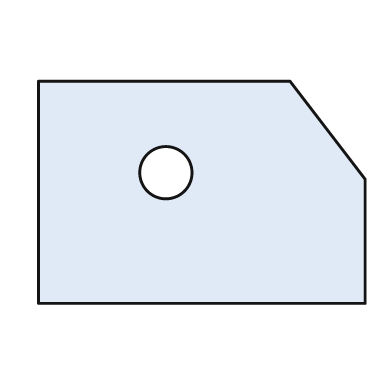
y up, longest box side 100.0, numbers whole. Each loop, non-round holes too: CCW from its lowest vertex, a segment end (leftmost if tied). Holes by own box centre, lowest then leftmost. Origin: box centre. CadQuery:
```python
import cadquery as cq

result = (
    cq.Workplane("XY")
    .moveTo(-50.0, -34.0)
    .lineTo(50.0, -34.0)
    .lineTo(50.0, 4.0)
    .lineTo(27.0, 34.0)
    .lineTo(-50.0, 34.0)
    .close()
    .moveTo(-11.0, 6.0)
    .circle(8.0)
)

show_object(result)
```